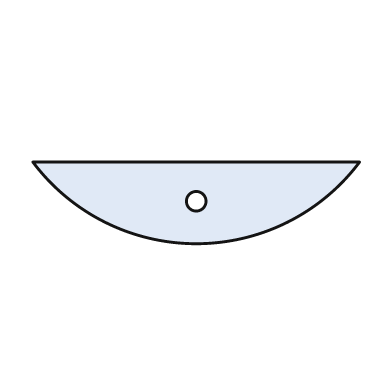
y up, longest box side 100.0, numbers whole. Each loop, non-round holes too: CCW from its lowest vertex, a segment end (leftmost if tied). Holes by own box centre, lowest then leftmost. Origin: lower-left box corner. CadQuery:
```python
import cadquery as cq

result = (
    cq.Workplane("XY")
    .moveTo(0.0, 25.0)
    .threePointArc((50.0, 0.0), (100.0, 25.0))
    .close()
    .moveTo(50.0, 13.0)
    .circle(3.0)
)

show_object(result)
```